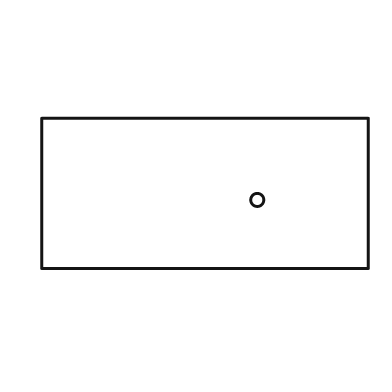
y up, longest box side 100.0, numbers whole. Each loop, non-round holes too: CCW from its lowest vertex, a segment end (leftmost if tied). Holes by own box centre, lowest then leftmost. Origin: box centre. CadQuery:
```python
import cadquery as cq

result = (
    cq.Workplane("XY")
    .moveTo(-50.0, -23.0)
    .lineTo(50.0, -23.0)
    .lineTo(50.0, 23.0)
    .lineTo(-50.0, 23.0)
    .close()
    .moveTo(16.0, -2.0)
    .circle(2.0)
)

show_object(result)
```